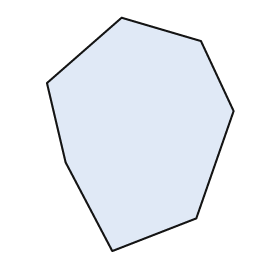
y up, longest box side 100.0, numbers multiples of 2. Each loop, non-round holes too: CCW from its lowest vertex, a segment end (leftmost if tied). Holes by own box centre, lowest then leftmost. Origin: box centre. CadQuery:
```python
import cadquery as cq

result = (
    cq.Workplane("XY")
    .moveTo(-12.0, -50.0)
    .lineTo(24.0, -36.0)
    .lineTo(40.0, 10.0)
    .lineTo(26.0, 40.0)
    .lineTo(-8.0, 50.0)
    .lineTo(-40.0, 22.0)
    .lineTo(-32.0, -12.0)
    .close()
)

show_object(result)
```